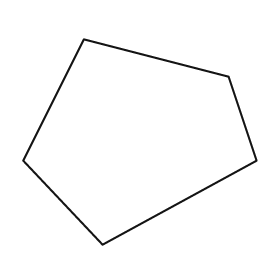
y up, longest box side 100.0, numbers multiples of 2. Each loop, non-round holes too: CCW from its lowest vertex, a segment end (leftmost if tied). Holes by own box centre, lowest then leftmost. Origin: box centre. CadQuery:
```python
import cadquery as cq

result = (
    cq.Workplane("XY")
    .moveTo(-16.0, -44.0)
    .lineTo(50.0, -8.0)
    .lineTo(38.0, 28.0)
    .lineTo(-24.0, 44.0)
    .lineTo(-50.0, -8.0)
    .close()
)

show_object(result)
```